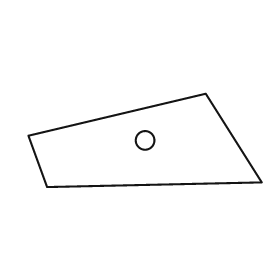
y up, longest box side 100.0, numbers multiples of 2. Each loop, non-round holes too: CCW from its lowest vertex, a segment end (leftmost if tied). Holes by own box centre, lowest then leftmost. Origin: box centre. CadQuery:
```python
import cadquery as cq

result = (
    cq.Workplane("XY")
    .moveTo(-42.0, -20.0)
    .lineTo(50.0, -18.0)
    .lineTo(26.0, 20.0)
    .lineTo(-50.0, 2.0)
    .close()
    .moveTo(0.0, 0.0)
    .circle(4.0)
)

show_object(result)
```